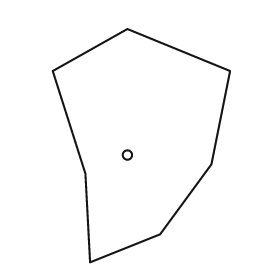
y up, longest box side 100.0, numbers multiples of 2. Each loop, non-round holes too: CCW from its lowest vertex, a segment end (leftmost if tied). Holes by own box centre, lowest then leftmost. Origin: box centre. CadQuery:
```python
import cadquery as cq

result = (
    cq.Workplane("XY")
    .moveTo(-22.0, -50.0)
    .lineTo(8.0, -38.0)
    .lineTo(30.0, -8.0)
    .lineTo(38.0, 32.0)
    .lineTo(-6.0, 50.0)
    .lineTo(-38.0, 32.0)
    .lineTo(-24.0, -12.0)
    .close()
    .moveTo(-6.0, -4.0)
    .circle(2.0)
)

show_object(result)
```